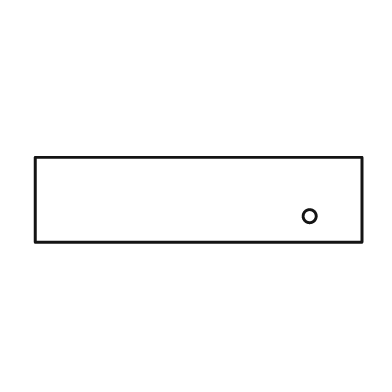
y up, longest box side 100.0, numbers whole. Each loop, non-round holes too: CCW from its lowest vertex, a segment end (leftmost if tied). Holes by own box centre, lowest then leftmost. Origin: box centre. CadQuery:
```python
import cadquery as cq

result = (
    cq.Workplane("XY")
    .moveTo(-50.0, -13.0)
    .lineTo(50.0, -13.0)
    .lineTo(50.0, 13.0)
    .lineTo(-50.0, 13.0)
    .close()
    .moveTo(34.0, -5.0)
    .circle(2.0)
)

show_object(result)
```